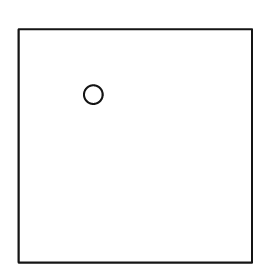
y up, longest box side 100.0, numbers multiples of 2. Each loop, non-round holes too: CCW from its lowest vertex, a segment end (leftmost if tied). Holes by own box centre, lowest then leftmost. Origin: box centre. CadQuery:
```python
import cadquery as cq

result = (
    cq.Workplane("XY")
    .moveTo(-50.0, -50.0)
    .lineTo(50.0, -50.0)
    .lineTo(50.0, 50.0)
    .lineTo(-50.0, 50.0)
    .close()
    .moveTo(-18.0, 22.0)
    .circle(4.0)
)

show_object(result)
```